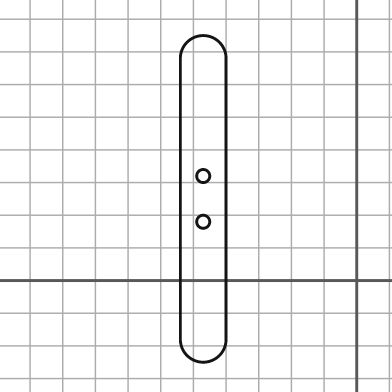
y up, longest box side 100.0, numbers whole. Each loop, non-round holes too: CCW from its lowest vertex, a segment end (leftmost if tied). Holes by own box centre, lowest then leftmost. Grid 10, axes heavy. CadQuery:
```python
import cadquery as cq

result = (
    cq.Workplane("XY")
    .moveTo(-54.0, -18.0)
    .threePointArc((-47.0, -25.0), (-40.0, -18.0))
    .lineTo(-40.0, 68.0)
    .threePointArc((-47.0, 75.0), (-54.0, 68.0))
    .close()
    .moveTo(-47.0, 18.0)
    .circle(2.0)
    .moveTo(-47.0, 32.0)
    .circle(2.0)
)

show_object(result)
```